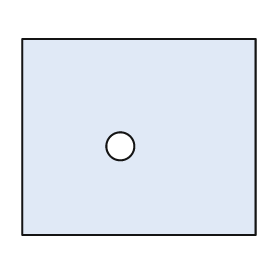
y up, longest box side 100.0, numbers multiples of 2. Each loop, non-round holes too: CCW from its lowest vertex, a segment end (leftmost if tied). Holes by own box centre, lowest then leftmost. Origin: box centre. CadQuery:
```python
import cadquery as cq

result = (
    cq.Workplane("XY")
    .moveTo(-50.0, -42.0)
    .lineTo(50.0, -42.0)
    .lineTo(50.0, 42.0)
    .lineTo(-50.0, 42.0)
    .close()
    .moveTo(-8.0, -4.0)
    .circle(6.0)
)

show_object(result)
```